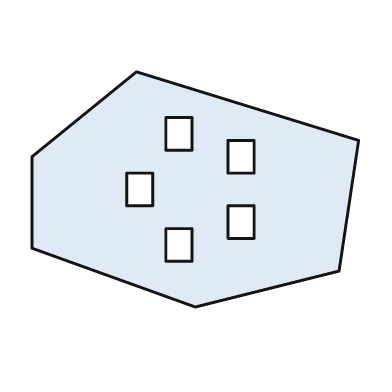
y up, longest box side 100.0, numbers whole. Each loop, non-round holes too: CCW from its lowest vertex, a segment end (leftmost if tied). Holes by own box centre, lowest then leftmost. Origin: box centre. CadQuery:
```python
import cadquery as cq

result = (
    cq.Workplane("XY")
    .moveTo(0.0, -36.0)
    .lineTo(44.0, -25.0)
    .lineTo(50.0, 15.0)
    .lineTo(-18.0, 36.0)
    .lineTo(-50.0, 10.0)
    .lineTo(-50.0, -18.0)
    .close()
    .moveTo(-9.0, -22.0)
    .lineTo(-1.0, -22.0)
    .lineTo(-1.0, -12.0)
    .lineTo(-9.0, -12.0)
    .close()
    .moveTo(10.0, -15.0)
    .lineTo(18.0, -15.0)
    .lineTo(18.0, -5.0)
    .lineTo(10.0, -5.0)
    .close()
    .moveTo(-21.0, -5.0)
    .lineTo(-13.0, -5.0)
    .lineTo(-13.0, 5.0)
    .lineTo(-21.0, 5.0)
    .close()
    .moveTo(10.0, 5.0)
    .lineTo(18.0, 5.0)
    .lineTo(18.0, 15.0)
    .lineTo(10.0, 15.0)
    .close()
    .moveTo(-9.0, 12.0)
    .lineTo(-1.0, 12.0)
    .lineTo(-1.0, 22.0)
    .lineTo(-9.0, 22.0)
    .close()
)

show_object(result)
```